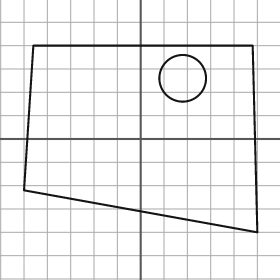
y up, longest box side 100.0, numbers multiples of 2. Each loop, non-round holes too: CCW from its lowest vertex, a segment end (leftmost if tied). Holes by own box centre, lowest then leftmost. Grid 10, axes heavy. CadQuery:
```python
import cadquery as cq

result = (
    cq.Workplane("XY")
    .moveTo(50.0, -40.0)
    .lineTo(48.0, 40.0)
    .lineTo(-46.0, 40.0)
    .lineTo(-50.0, -22.0)
    .close()
    .moveTo(18.0, 26.0)
    .circle(10.0)
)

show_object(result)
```